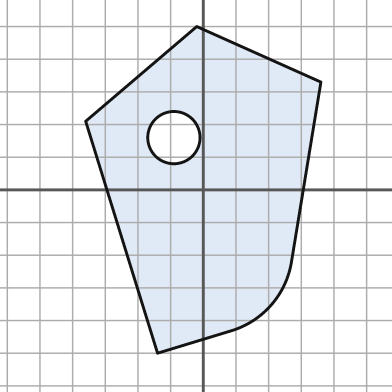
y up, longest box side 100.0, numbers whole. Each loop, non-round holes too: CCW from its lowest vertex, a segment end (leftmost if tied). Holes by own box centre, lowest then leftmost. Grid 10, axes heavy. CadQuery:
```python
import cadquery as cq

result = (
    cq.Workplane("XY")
    .moveTo(-14.0, -50.0)
    .lineTo(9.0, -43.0)
    .threePointArc((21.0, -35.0), (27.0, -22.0))
    .lineTo(36.0, 33.0)
    .lineTo(-2.0, 50.0)
    .lineTo(-36.0, 21.0)
    .close()
    .moveTo(-9.0, 16.0)
    .circle(8.0)
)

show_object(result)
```